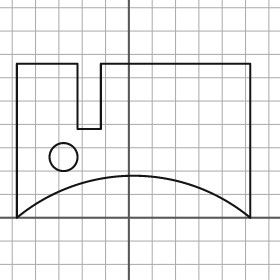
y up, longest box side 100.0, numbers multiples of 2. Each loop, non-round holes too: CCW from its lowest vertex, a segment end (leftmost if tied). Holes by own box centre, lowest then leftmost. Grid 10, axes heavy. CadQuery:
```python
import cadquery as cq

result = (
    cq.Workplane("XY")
    .moveTo(-48.0, 0.0)
    .threePointArc((2.0, 18.0), (52.0, 0.0))
    .lineTo(52.0, 66.0)
    .lineTo(-12.0, 66.0)
    .lineTo(-12.0, 38.0)
    .lineTo(-22.0, 38.0)
    .lineTo(-22.0, 66.0)
    .lineTo(-48.0, 66.0)
    .close()
    .moveTo(-28.0, 26.0)
    .circle(6.0)
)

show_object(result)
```